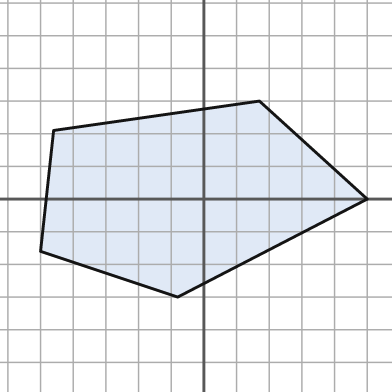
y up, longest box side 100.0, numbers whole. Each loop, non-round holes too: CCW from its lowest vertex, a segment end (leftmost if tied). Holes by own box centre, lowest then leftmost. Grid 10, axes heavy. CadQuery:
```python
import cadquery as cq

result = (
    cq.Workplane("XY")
    .moveTo(-8.0, -30.0)
    .lineTo(50.0, 0.0)
    .lineTo(17.0, 30.0)
    .lineTo(-46.0, 21.0)
    .lineTo(-50.0, -16.0)
    .close()
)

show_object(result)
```